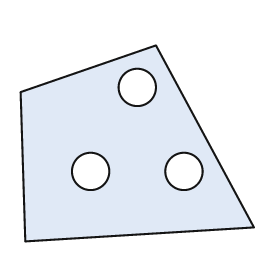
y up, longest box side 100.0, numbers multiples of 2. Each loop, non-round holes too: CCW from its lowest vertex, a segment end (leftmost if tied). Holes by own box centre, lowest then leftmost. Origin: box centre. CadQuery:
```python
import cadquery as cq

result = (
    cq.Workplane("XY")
    .moveTo(-48.0, -42.0)
    .lineTo(50.0, -36.0)
    .lineTo(8.0, 42.0)
    .lineTo(-50.0, 22.0)
    .close()
    .moveTo(-20.0, -12.0)
    .circle(8.0)
    .moveTo(20.0, -12.0)
    .circle(8.0)
    .moveTo(0.0, 24.0)
    .circle(8.0)
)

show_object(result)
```